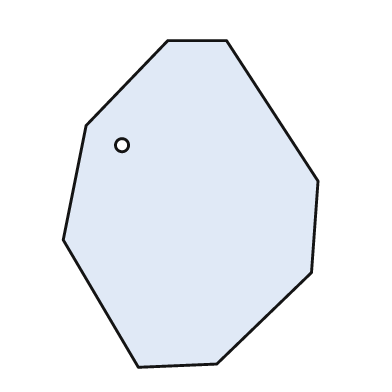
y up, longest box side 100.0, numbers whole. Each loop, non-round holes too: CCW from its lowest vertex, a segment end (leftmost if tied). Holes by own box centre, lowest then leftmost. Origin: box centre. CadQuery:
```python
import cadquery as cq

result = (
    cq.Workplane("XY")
    .moveTo(-16.0, -50.0)
    .lineTo(8.0, -49.0)
    .lineTo(37.0, -21.0)
    .lineTo(39.0, 7.0)
    .lineTo(11.0, 50.0)
    .lineTo(-7.0, 50.0)
    .lineTo(-32.0, 24.0)
    .lineTo(-39.0, -11.0)
    .close()
    .moveTo(-21.0, 18.0)
    .circle(2.0)
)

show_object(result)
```